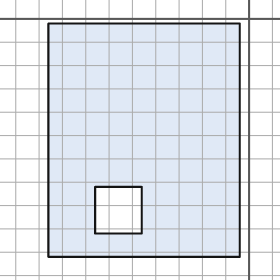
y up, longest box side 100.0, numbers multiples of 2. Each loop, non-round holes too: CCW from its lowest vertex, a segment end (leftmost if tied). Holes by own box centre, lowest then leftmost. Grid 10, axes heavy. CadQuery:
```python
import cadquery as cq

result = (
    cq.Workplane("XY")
    .moveTo(-86.0, -102.0)
    .lineTo(-4.0, -102.0)
    .lineTo(-4.0, -2.0)
    .lineTo(-86.0, -2.0)
    .close()
    .moveTo(-66.0, -92.0)
    .lineTo(-46.0, -92.0)
    .lineTo(-46.0, -72.0)
    .lineTo(-66.0, -72.0)
    .close()
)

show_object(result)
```